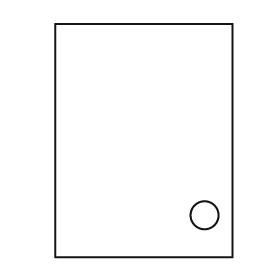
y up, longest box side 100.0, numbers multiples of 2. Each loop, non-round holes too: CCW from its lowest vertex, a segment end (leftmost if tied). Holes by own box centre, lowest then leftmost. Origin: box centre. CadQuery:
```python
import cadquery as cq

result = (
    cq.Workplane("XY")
    .moveTo(-38.0, -50.0)
    .lineTo(38.0, -50.0)
    .lineTo(38.0, 50.0)
    .lineTo(-38.0, 50.0)
    .close()
    .moveTo(26.0, -32.0)
    .circle(6.0)
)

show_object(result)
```